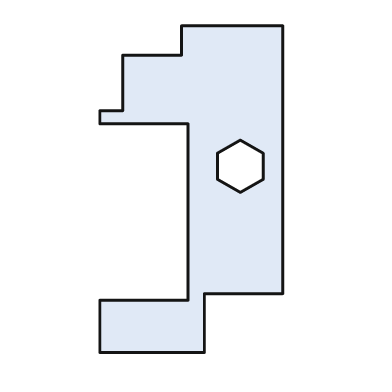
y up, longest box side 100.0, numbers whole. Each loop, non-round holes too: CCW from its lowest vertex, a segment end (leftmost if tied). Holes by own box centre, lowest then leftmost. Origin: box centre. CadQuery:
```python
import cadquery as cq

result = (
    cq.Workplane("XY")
    .moveTo(-28.0, -50.0)
    .lineTo(4.0, -50.0)
    .lineTo(4.0, -32.0)
    .lineTo(28.0, -32.0)
    .lineTo(28.0, 50.0)
    .lineTo(-3.0, 50.0)
    .lineTo(-3.0, 41.0)
    .lineTo(-21.0, 41.0)
    .lineTo(-21.0, 24.0)
    .lineTo(-28.0, 24.0)
    .lineTo(-28.0, 20.0)
    .lineTo(-1.0, 20.0)
    .lineTo(-1.0, -34.0)
    .lineTo(-28.0, -34.0)
    .close()
    .moveTo(15.0, -1.0)
    .lineTo(22.0, 3.0)
    .lineTo(22.0, 11.0)
    .lineTo(15.0, 15.0)
    .lineTo(8.0, 11.0)
    .lineTo(8.0, 3.0)
    .close()
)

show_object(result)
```